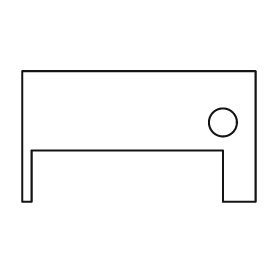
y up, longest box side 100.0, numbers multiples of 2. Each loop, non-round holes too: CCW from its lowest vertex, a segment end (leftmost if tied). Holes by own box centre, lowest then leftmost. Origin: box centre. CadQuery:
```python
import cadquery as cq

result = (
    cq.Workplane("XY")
    .moveTo(-50.0, -28.0)
    .lineTo(-46.0, -28.0)
    .lineTo(-46.0, -6.0)
    .lineTo(36.0, -6.0)
    .lineTo(36.0, -28.0)
    .lineTo(50.0, -28.0)
    .lineTo(50.0, 28.0)
    .lineTo(-50.0, 28.0)
    .close()
    .moveTo(36.0, 6.0)
    .circle(6.0)
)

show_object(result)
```